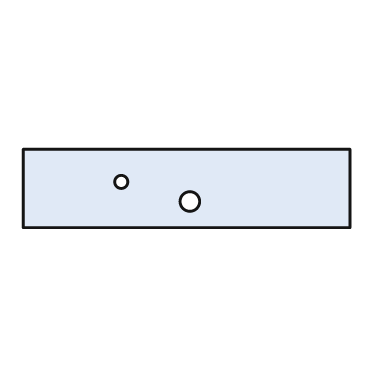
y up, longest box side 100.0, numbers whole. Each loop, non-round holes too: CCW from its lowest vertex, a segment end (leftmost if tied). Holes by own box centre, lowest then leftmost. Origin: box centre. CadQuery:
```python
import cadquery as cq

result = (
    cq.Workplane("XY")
    .moveTo(-50.0, -12.0)
    .lineTo(50.0, -12.0)
    .lineTo(50.0, 12.0)
    .lineTo(-50.0, 12.0)
    .close()
    .moveTo(1.0, -4.0)
    .circle(3.0)
    .moveTo(-20.0, 2.0)
    .circle(2.0)
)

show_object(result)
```